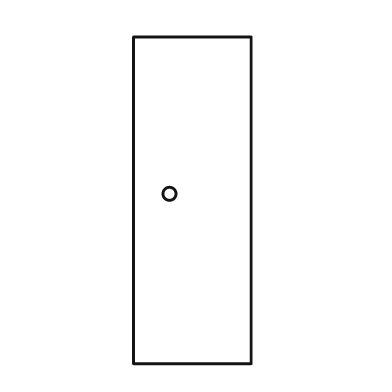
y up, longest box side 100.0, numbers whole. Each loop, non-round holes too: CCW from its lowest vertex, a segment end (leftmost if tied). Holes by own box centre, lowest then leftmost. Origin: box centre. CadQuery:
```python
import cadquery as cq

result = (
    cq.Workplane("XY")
    .moveTo(-18.0, -50.0)
    .lineTo(18.0, -50.0)
    .lineTo(18.0, 50.0)
    .lineTo(-18.0, 50.0)
    .close()
    .moveTo(-7.0, 2.0)
    .circle(2.0)
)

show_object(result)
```